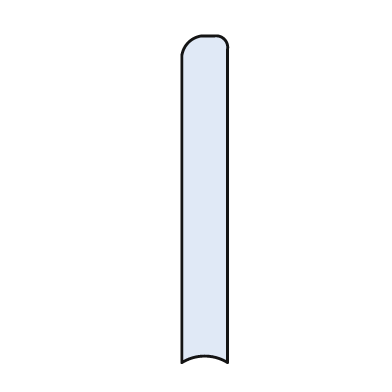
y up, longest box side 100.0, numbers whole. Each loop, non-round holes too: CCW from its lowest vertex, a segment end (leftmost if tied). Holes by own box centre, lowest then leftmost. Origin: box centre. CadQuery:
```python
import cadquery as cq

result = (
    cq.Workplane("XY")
    .moveTo(-7.0, -50.0)
    .threePointArc((0.0, -48.0), (7.0, -50.0))
    .lineTo(7.0, 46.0)
    .threePointArc((6.0, 49.0), (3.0, 50.0))
    .lineTo(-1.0, 50.0)
    .threePointArc((-5.0, 48.0), (-7.0, 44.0))
    .close()
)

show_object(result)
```